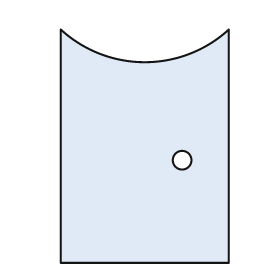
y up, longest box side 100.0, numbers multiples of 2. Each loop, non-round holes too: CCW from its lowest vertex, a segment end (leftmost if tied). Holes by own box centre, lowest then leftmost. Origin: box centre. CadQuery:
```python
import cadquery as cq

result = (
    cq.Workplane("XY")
    .moveTo(-36.0, -50.0)
    .lineTo(36.0, -50.0)
    .lineTo(36.0, 50.0)
    .threePointArc((0.0, 36.0), (-36.0, 50.0))
    .close()
    .moveTo(16.0, -6.0)
    .circle(4.0)
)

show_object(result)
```